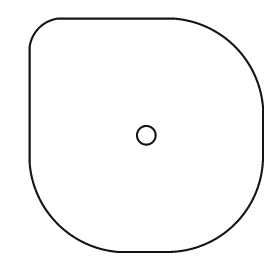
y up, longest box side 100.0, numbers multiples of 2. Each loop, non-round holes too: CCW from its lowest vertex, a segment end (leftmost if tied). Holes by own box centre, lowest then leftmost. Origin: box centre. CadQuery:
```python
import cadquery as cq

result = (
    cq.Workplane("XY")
    .moveTo(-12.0, -50.0)
    .lineTo(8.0, -50.0)
    .threePointArc((38.0, -38.0), (50.0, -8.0))
    .lineTo(50.0, 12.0)
    .threePointArc((38.0, 38.0), (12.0, 50.0))
    .lineTo(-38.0, 50.0)
    .threePointArc((-46.0, 46.0), (-50.0, 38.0))
    .lineTo(-50.0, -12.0)
    .threePointArc((-38.0, -38.0), (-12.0, -50.0))
    .close()
    .moveTo(0.0, 0.0)
    .circle(4.0)
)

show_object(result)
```